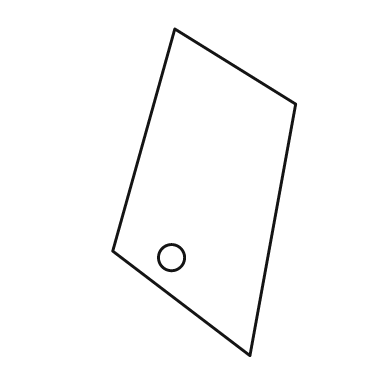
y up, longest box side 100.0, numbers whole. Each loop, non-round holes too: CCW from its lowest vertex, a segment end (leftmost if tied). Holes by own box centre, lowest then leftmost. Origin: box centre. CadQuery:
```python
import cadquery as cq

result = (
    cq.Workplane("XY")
    .moveTo(14.0, -50.0)
    .lineTo(28.0, 27.0)
    .lineTo(-9.0, 50.0)
    .lineTo(-28.0, -18.0)
    .close()
    .moveTo(-10.0, -20.0)
    .circle(4.0)
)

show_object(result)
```